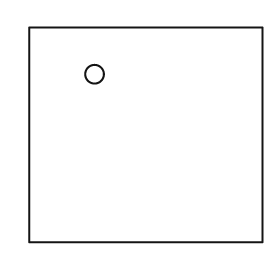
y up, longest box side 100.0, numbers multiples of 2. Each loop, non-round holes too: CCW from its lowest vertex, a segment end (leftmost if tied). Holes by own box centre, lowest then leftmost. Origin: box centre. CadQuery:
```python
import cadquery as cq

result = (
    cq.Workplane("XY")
    .moveTo(-50.0, -46.0)
    .lineTo(50.0, -46.0)
    .lineTo(50.0, 46.0)
    .lineTo(-50.0, 46.0)
    .close()
    .moveTo(-22.0, 26.0)
    .circle(4.0)
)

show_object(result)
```